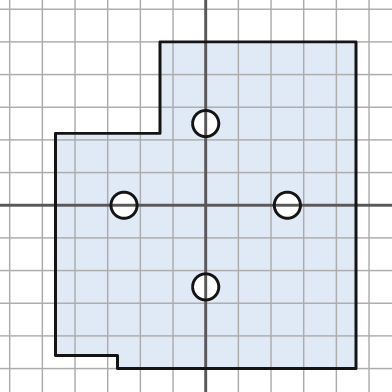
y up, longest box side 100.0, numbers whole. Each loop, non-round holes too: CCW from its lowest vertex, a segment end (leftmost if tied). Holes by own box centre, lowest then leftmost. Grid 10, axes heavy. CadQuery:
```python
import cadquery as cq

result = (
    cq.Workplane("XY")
    .moveTo(-27.0, -50.0)
    .lineTo(46.0, -50.0)
    .lineTo(46.0, 50.0)
    .lineTo(-14.0, 50.0)
    .lineTo(-14.0, 22.0)
    .lineTo(-46.0, 22.0)
    .lineTo(-46.0, -46.0)
    .lineTo(-27.0, -46.0)
    .close()
    .moveTo(0.0, -25.0)
    .circle(4.0)
    .moveTo(-25.0, 0.0)
    .circle(4.0)
    .moveTo(25.0, 0.0)
    .circle(4.0)
    .moveTo(0.0, 25.0)
    .circle(4.0)
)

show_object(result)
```